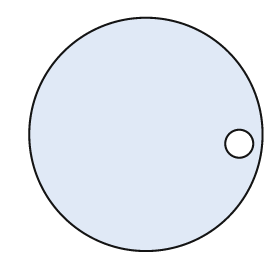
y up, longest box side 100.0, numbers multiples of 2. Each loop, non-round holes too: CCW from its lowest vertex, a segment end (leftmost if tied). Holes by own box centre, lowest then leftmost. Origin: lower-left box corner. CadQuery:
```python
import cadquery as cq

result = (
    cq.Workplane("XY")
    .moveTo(50.0, 50.0)
    .circle(50.0)
    .moveTo(90.0, 46.0)
    .circle(6.0)
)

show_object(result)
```